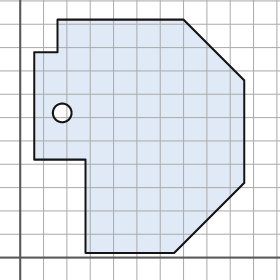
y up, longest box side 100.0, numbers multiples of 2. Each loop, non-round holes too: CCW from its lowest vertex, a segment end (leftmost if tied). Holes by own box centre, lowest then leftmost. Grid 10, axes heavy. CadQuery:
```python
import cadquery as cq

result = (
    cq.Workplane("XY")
    .moveTo(28.0, 2.0)
    .lineTo(66.0, 2.0)
    .lineTo(96.0, 32.0)
    .lineTo(96.0, 76.0)
    .lineTo(70.0, 102.0)
    .lineTo(16.0, 102.0)
    .lineTo(16.0, 88.0)
    .lineTo(6.0, 88.0)
    .lineTo(6.0, 42.0)
    .lineTo(28.0, 42.0)
    .close()
    .moveTo(18.0, 62.0)
    .circle(4.0)
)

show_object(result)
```